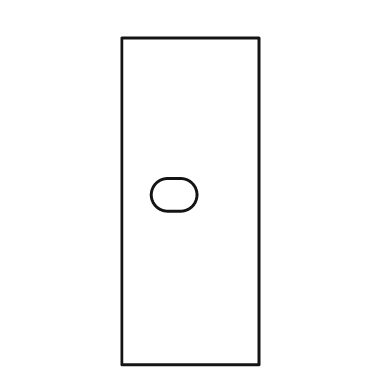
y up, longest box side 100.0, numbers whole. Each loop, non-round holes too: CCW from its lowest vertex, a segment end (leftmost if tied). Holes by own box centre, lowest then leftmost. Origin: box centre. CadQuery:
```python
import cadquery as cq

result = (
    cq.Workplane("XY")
    .moveTo(-21.0, -50.0)
    .lineTo(21.0, -50.0)
    .lineTo(21.0, 50.0)
    .lineTo(-21.0, 50.0)
    .close()
    .moveTo(-7.0, -3.0)
    .lineTo(-3.0, -3.0)
    .threePointArc((2.0, 2.0), (-3.0, 7.0))
    .lineTo(-7.0, 7.0)
    .threePointArc((-12.0, 2.0), (-7.0, -3.0))
    .close()
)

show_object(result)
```